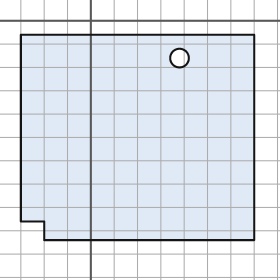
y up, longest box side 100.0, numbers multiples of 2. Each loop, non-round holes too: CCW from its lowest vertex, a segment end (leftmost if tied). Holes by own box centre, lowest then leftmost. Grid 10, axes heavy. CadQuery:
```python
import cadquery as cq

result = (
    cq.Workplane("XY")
    .moveTo(-20.0, -94.0)
    .lineTo(70.0, -94.0)
    .lineTo(70.0, -6.0)
    .lineTo(-30.0, -6.0)
    .lineTo(-30.0, -86.0)
    .lineTo(-20.0, -86.0)
    .close()
    .moveTo(38.0, -16.0)
    .circle(4.0)
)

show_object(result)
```